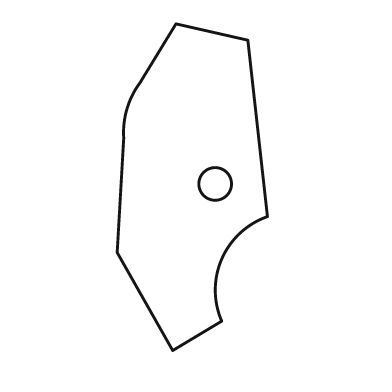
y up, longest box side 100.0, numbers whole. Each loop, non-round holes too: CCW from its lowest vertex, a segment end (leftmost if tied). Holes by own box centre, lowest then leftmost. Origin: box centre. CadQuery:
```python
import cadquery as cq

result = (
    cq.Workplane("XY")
    .moveTo(-6.0, -50.0)
    .lineTo(9.0, -41.0)
    .threePointArc((9.0, -22.0), (23.0, -9.0))
    .lineTo(17.0, 45.0)
    .lineTo(-5.0, 50.0)
    .lineTo(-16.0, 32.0)
    .threePointArc((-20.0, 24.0), (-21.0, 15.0))
    .lineTo(-23.0, -20.0)
    .close()
    .moveTo(7.0, 1.0)
    .circle(5.0)
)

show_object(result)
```